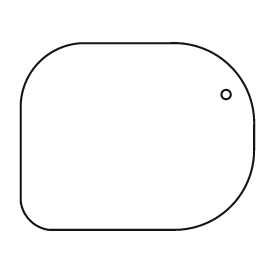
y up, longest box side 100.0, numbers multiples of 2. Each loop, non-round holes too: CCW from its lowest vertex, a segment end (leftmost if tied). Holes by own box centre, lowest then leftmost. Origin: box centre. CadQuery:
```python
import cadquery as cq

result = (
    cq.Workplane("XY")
    .moveTo(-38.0, -40.0)
    .lineTo(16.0, -40.0)
    .threePointArc((40.0, -30.0), (50.0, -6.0))
    .lineTo(50.0, 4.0)
    .threePointArc((40.0, 30.0), (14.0, 40.0))
    .lineTo(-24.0, 40.0)
    .threePointArc((-42.0, 32.0), (-50.0, 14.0))
    .lineTo(-50.0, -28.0)
    .threePointArc((-46.0, -36.0), (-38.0, -40.0))
    .close()
    .moveTo(38.0, 18.0)
    .circle(2.0)
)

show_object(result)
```